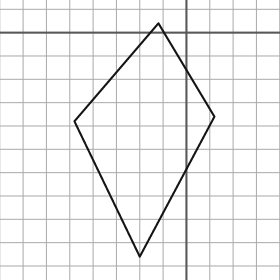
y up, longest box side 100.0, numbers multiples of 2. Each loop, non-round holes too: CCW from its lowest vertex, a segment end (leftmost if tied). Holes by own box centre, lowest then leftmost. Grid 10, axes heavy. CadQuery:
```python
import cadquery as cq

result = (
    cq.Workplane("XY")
    .moveTo(-20.0, -96.0)
    .lineTo(12.0, -36.0)
    .lineTo(-12.0, 4.0)
    .lineTo(-48.0, -38.0)
    .close()
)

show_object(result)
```